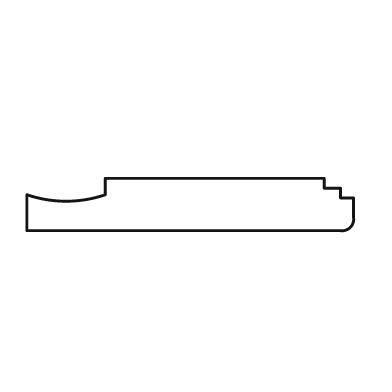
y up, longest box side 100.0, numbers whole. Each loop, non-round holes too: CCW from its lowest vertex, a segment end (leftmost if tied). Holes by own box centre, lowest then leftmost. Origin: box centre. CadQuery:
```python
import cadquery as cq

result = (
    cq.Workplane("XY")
    .moveTo(-50.0, -8.0)
    .lineTo(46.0, -8.0)
    .threePointArc((49.0, -7.0), (50.0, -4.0))
    .lineTo(50.0, 2.0)
    .lineTo(46.0, 2.0)
    .lineTo(46.0, 5.0)
    .lineTo(41.0, 5.0)
    .lineTo(41.0, 8.0)
    .lineTo(-26.0, 8.0)
    .lineTo(-26.0, 3.0)
    .threePointArc((-38.0, 1.0), (-50.0, 3.0))
    .close()
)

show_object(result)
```